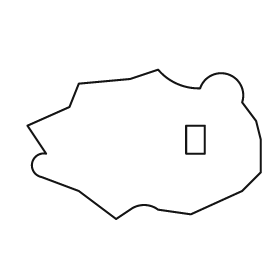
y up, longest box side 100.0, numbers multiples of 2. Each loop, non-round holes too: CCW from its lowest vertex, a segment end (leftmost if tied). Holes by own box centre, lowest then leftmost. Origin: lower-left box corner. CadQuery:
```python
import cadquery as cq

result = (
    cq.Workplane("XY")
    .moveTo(38.0, 0.0)
    .lineTo(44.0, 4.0)
    .threePointArc((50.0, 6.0), (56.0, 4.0))
    .lineTo(70.0, 2.0)
    .lineTo(92.0, 12.0)
    .lineTo(100.0, 20.0)
    .lineTo(100.0, 34.0)
    .lineTo(98.0, 42.0)
    .lineTo(92.0, 50.0)
    .threePointArc((86.0, 62.0), (74.0, 56.0))
    .threePointArc((64.0, 58.0), (56.0, 64.0))
    .lineTo(44.0, 60.0)
    .lineTo(22.0, 58.0)
    .lineTo(18.0, 48.0)
    .lineTo(0.0, 40.0)
    .lineTo(8.0, 28.0)
    .threePointArc((2.0, 24.0), (6.0, 18.0))
    .lineTo(22.0, 12.0)
    .close()
    .moveTo(68.0, 28.0)
    .lineTo(76.0, 28.0)
    .lineTo(76.0, 40.0)
    .lineTo(68.0, 40.0)
    .close()
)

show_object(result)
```